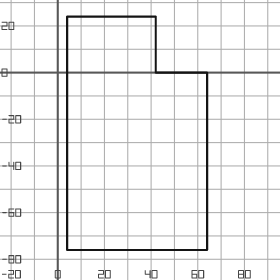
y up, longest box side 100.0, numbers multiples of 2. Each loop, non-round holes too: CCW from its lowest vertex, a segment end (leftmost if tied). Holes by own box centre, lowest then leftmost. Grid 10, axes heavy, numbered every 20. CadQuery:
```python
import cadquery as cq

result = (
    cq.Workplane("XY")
    .moveTo(4.0, -76.0)
    .lineTo(64.0, -76.0)
    .lineTo(64.0, 0.0)
    .lineTo(42.0, 0.0)
    .lineTo(42.0, 24.0)
    .lineTo(4.0, 24.0)
    .close()
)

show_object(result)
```